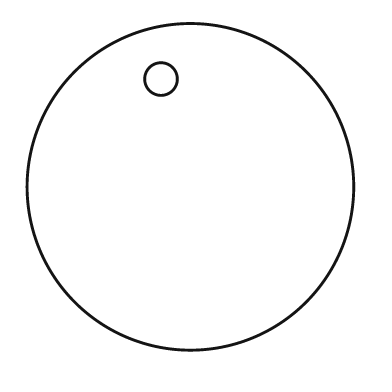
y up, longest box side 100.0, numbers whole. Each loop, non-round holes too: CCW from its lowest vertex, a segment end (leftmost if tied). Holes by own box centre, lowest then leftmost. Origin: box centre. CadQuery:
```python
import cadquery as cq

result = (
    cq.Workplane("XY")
    .moveTo(0.0, 0.0)
    .circle(50.0)
    .moveTo(-9.0, 33.0)
    .circle(5.0)
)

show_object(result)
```